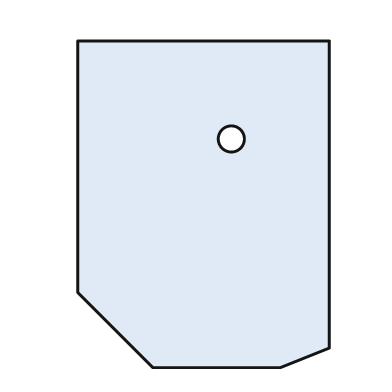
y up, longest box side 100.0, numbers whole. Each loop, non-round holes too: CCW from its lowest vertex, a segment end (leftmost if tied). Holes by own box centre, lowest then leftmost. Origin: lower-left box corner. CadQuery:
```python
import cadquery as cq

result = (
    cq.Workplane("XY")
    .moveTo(23.0, 0.0)
    .lineTo(62.0, 0.0)
    .lineTo(77.0, 6.0)
    .lineTo(77.0, 100.0)
    .lineTo(0.0, 100.0)
    .lineTo(0.0, 23.0)
    .close()
    .moveTo(47.0, 70.0)
    .circle(4.0)
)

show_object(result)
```